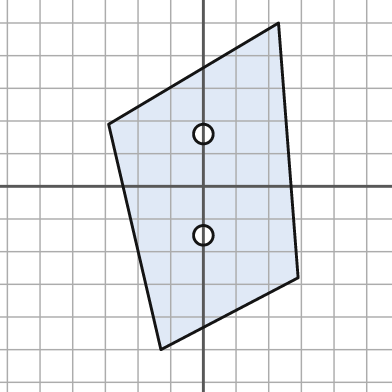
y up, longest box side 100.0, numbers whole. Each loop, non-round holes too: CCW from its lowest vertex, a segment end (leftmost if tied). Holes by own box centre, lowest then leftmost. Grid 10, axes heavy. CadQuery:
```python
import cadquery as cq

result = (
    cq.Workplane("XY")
    .moveTo(-13.0, -50.0)
    .lineTo(29.0, -28.0)
    .lineTo(23.0, 50.0)
    .lineTo(-29.0, 19.0)
    .close()
    .moveTo(0.0, -15.0)
    .circle(3.0)
    .moveTo(0.0, 16.0)
    .circle(3.0)
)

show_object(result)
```